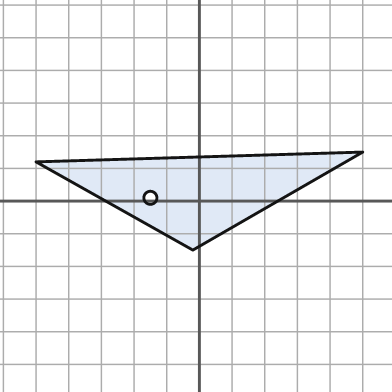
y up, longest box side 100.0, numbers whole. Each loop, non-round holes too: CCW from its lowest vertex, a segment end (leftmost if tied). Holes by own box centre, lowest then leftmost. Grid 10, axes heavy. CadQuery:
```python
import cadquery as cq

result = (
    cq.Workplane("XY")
    .moveTo(-2.0, -15.0)
    .lineTo(50.0, 15.0)
    .lineTo(-50.0, 12.0)
    .close()
    .moveTo(-15.0, 1.0)
    .circle(2.0)
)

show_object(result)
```